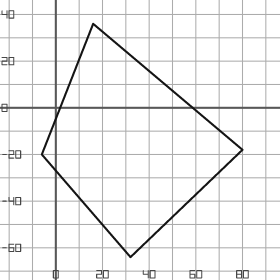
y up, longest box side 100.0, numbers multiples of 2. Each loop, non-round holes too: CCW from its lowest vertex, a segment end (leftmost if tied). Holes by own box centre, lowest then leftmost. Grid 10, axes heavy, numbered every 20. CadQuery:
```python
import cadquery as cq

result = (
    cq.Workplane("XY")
    .moveTo(32.0, -64.0)
    .lineTo(80.0, -18.0)
    .lineTo(16.0, 36.0)
    .lineTo(-6.0, -20.0)
    .close()
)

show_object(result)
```